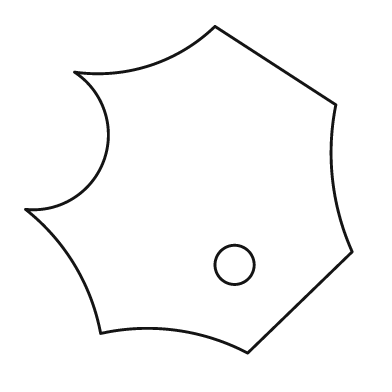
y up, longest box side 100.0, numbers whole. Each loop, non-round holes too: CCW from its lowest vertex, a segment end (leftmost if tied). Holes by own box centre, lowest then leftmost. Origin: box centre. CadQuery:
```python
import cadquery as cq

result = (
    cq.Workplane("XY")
    .moveTo(18.0, -50.0)
    .lineTo(50.0, -19.0)
    .threePointArc((44.0, 3.0), (45.0, 26.0))
    .lineTo(8.0, 50.0)
    .threePointArc((-12.0, 38.0), (-35.0, 36.0))
    .threePointArc((-26.0, 9.0), (-50.0, -6.0))
    .threePointArc((-35.0, -23.0), (-27.0, -44.0))
    .threePointArc((-4.0, -43.0), (18.0, -50.0))
    .close()
    .moveTo(14.0, -23.0)
    .circle(6.0)
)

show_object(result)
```